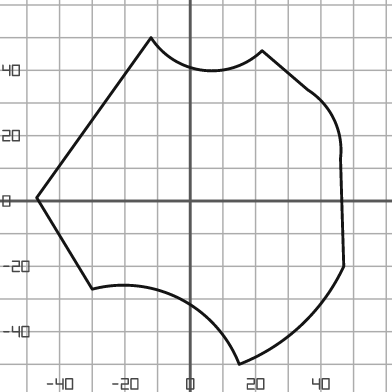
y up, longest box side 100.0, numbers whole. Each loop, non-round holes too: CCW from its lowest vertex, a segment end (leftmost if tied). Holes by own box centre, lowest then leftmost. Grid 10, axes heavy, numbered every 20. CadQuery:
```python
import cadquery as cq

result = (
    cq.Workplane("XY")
    .moveTo(15.0, -50.0)
    .threePointArc((34.0, -38.0), (47.0, -20.0))
    .lineTo(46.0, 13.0)
    .threePointArc((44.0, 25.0), (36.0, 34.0))
    .lineTo(22.0, 46.0)
    .threePointArc((4.0, 40.0), (-12.0, 50.0))
    .lineTo(-47.0, 1.0)
    .lineTo(-30.0, -27.0)
    .threePointArc((-3.0, -30.0), (15.0, -50.0))
    .close()
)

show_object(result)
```